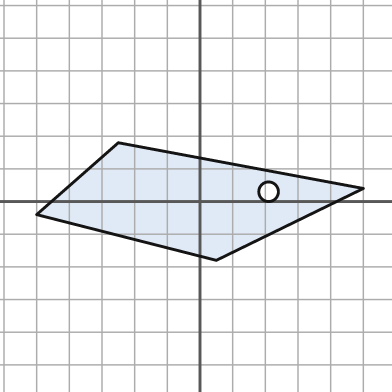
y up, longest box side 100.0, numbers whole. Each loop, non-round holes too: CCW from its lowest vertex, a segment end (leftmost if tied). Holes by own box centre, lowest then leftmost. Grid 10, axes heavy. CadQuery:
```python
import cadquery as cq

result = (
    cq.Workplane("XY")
    .moveTo(5.0, -18.0)
    .lineTo(50.0, 4.0)
    .lineTo(-25.0, 18.0)
    .lineTo(-50.0, -4.0)
    .close()
    .moveTo(21.0, 3.0)
    .circle(3.0)
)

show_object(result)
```